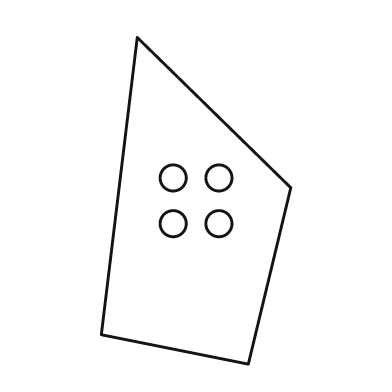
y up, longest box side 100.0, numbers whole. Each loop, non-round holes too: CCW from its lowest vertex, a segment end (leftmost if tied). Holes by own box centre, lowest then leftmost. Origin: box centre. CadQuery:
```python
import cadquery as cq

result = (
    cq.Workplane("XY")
    .moveTo(16.0, -50.0)
    .lineTo(29.0, 4.0)
    .lineTo(-18.0, 50.0)
    .lineTo(-29.0, -41.0)
    .close()
    .moveTo(-7.0, -7.0)
    .circle(4.0)
    .moveTo(7.0, -7.0)
    .circle(4.0)
    .moveTo(-7.0, 7.0)
    .circle(4.0)
    .moveTo(7.0, 7.0)
    .circle(4.0)
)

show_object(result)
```